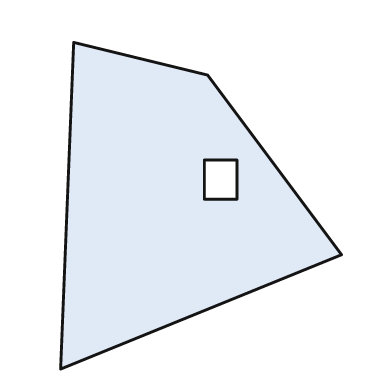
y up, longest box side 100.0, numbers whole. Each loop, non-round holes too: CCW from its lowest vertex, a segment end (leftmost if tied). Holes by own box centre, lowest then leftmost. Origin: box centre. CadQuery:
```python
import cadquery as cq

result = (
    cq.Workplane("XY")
    .moveTo(-43.0, -50.0)
    .lineTo(43.0, -15.0)
    .lineTo(2.0, 40.0)
    .lineTo(-39.0, 50.0)
    .close()
    .moveTo(1.0, 2.0)
    .lineTo(11.0, 2.0)
    .lineTo(11.0, 14.0)
    .lineTo(1.0, 14.0)
    .close()
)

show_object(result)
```